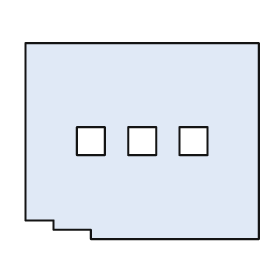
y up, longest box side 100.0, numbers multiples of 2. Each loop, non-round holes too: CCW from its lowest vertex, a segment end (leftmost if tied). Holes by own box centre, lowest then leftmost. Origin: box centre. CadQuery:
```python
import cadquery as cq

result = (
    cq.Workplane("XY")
    .moveTo(-22.0, -42.0)
    .lineTo(50.0, -42.0)
    .lineTo(50.0, 42.0)
    .lineTo(-50.0, 42.0)
    .lineTo(-50.0, -34.0)
    .lineTo(-38.0, -34.0)
    .lineTo(-38.0, -38.0)
    .lineTo(-22.0, -38.0)
    .close()
    .moveTo(-28.0, -6.0)
    .lineTo(-16.0, -6.0)
    .lineTo(-16.0, 6.0)
    .lineTo(-28.0, 6.0)
    .close()
    .moveTo(-6.0, -6.0)
    .lineTo(6.0, -6.0)
    .lineTo(6.0, 6.0)
    .lineTo(-6.0, 6.0)
    .close()
    .moveTo(16.0, -6.0)
    .lineTo(28.0, -6.0)
    .lineTo(28.0, 6.0)
    .lineTo(16.0, 6.0)
    .close()
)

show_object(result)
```